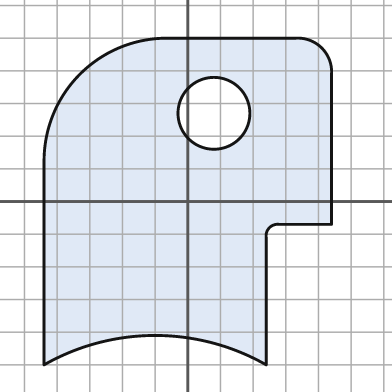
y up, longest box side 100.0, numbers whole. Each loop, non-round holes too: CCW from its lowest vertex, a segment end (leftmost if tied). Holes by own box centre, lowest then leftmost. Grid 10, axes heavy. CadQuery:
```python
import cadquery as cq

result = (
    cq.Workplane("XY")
    .moveTo(-44.0, -50.0)
    .threePointArc((-10.0, -41.0), (24.0, -50.0))
    .lineTo(24.0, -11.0)
    .threePointArc((25.0, -8.0), (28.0, -7.0))
    .lineTo(44.0, -7.0)
    .lineTo(44.0, 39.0)
    .threePointArc((41.0, 47.0), (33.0, 50.0))
    .lineTo(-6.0, 50.0)
    .threePointArc((-33.0, 39.0), (-44.0, 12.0))
    .close()
    .moveTo(8.0, 27.0)
    .circle(11.0)
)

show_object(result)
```